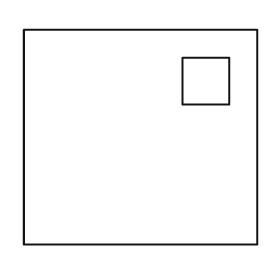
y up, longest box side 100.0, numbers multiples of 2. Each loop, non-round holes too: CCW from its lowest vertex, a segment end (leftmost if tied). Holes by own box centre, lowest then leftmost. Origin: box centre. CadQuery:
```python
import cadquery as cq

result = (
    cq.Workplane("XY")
    .moveTo(-50.0, -46.0)
    .lineTo(50.0, -46.0)
    .lineTo(50.0, 46.0)
    .lineTo(-50.0, 46.0)
    .close()
    .moveTo(18.0, 14.0)
    .lineTo(38.0, 14.0)
    .lineTo(38.0, 34.0)
    .lineTo(18.0, 34.0)
    .close()
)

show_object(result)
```